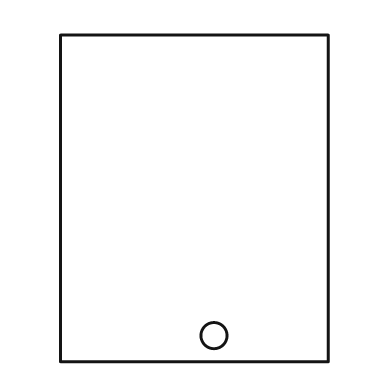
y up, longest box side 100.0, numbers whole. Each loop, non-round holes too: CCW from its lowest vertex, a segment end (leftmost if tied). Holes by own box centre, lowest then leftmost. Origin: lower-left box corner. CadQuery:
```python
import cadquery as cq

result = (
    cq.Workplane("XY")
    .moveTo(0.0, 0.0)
    .lineTo(82.0, 0.0)
    .lineTo(82.0, 100.0)
    .lineTo(0.0, 100.0)
    .close()
    .moveTo(47.0, 8.0)
    .circle(4.0)
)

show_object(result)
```